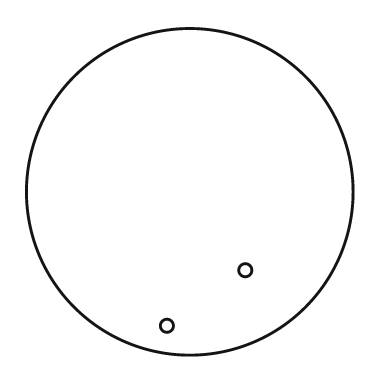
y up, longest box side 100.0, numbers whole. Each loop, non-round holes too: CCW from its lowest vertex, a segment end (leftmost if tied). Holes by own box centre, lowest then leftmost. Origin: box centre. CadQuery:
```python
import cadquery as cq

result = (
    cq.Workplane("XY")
    .moveTo(0.0, 0.0)
    .circle(50.0)
    .moveTo(-7.0, -41.0)
    .circle(2.0)
    .moveTo(17.0, -24.0)
    .circle(2.0)
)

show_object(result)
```